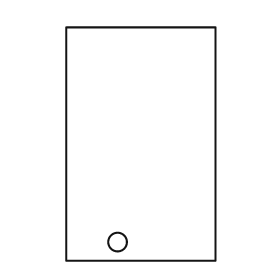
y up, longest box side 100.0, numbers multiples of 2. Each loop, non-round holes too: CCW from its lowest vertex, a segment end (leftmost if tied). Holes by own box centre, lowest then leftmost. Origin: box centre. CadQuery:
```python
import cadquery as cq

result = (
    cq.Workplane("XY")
    .moveTo(-32.0, -50.0)
    .lineTo(32.0, -50.0)
    .lineTo(32.0, 50.0)
    .lineTo(-32.0, 50.0)
    .close()
    .moveTo(-10.0, -42.0)
    .circle(4.0)
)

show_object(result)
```